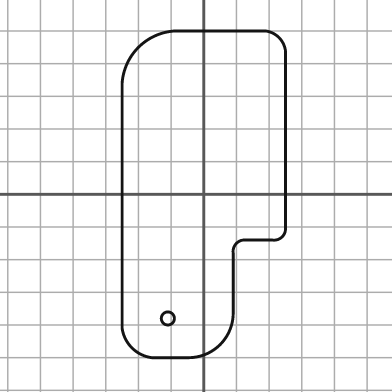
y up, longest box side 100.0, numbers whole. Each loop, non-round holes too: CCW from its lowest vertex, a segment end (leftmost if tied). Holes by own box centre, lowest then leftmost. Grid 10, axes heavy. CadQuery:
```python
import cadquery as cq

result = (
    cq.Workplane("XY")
    .moveTo(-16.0, -50.0)
    .lineTo(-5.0, -50.0)
    .threePointArc((5.0, -46.0), (9.0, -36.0))
    .lineTo(9.0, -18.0)
    .threePointArc((10.0, -15.0), (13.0, -14.0))
    .lineTo(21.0, -14.0)
    .threePointArc((24.0, -13.0), (25.0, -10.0))
    .lineTo(25.0, 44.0)
    .threePointArc((23.0, 48.0), (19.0, 50.0))
    .lineTo(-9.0, 50.0)
    .threePointArc((-20.0, 45.0), (-25.0, 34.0))
    .lineTo(-25.0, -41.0)
    .threePointArc((-22.0, -47.0), (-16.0, -50.0))
    .close()
    .moveTo(-11.0, -38.0)
    .circle(2.0)
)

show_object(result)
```